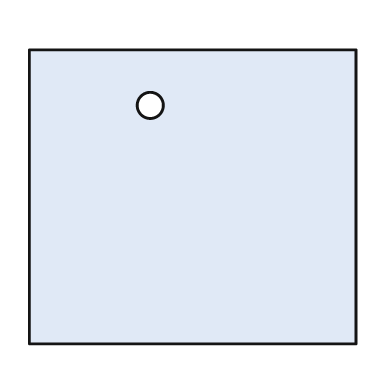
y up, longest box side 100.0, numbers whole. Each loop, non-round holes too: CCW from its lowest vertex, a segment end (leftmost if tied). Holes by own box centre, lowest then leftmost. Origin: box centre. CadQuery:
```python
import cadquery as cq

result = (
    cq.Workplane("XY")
    .moveTo(-50.0, -45.0)
    .lineTo(50.0, -45.0)
    .lineTo(50.0, 45.0)
    .lineTo(-50.0, 45.0)
    .close()
    .moveTo(-13.0, 28.0)
    .circle(4.0)
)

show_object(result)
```